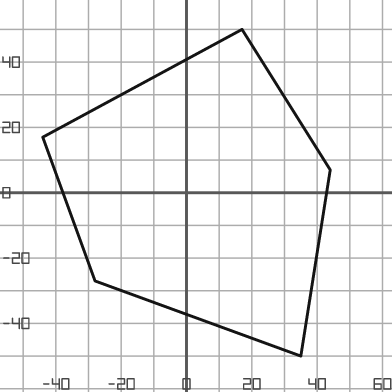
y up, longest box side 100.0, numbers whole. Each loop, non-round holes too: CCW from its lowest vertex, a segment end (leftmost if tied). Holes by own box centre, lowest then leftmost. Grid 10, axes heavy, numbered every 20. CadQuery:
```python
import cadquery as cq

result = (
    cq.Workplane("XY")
    .moveTo(35.0, -50.0)
    .lineTo(44.0, 7.0)
    .lineTo(17.0, 50.0)
    .lineTo(-44.0, 17.0)
    .lineTo(-28.0, -27.0)
    .close()
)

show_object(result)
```